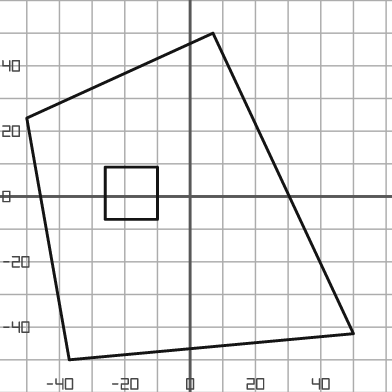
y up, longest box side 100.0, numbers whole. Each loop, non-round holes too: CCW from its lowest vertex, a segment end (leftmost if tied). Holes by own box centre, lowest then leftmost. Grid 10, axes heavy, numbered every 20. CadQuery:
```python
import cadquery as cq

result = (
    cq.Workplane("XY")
    .moveTo(-37.0, -50.0)
    .lineTo(50.0, -42.0)
    .lineTo(7.0, 50.0)
    .lineTo(-50.0, 24.0)
    .close()
    .moveTo(-26.0, -7.0)
    .lineTo(-10.0, -7.0)
    .lineTo(-10.0, 9.0)
    .lineTo(-26.0, 9.0)
    .close()
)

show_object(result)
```